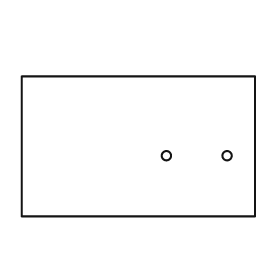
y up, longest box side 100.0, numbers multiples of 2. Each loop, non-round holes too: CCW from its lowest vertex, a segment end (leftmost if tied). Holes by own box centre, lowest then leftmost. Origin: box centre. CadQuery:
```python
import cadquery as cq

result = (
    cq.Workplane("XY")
    .moveTo(-50.0, -30.0)
    .lineTo(50.0, -30.0)
    .lineTo(50.0, 30.0)
    .lineTo(-50.0, 30.0)
    .close()
    .moveTo(12.0, -4.0)
    .circle(2.0)
    .moveTo(38.0, -4.0)
    .circle(2.0)
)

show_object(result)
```